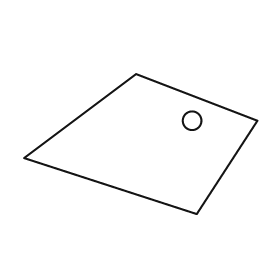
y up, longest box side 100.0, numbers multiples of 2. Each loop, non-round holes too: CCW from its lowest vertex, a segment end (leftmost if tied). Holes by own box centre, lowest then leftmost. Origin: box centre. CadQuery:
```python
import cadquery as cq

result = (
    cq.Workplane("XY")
    .moveTo(24.0, -30.0)
    .lineTo(50.0, 10.0)
    .lineTo(-2.0, 30.0)
    .lineTo(-50.0, -6.0)
    .close()
    .moveTo(22.0, 10.0)
    .circle(4.0)
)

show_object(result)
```